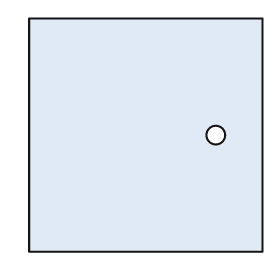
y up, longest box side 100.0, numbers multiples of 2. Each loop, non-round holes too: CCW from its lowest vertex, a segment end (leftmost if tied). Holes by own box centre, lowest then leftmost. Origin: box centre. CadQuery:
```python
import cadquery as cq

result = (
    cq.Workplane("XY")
    .moveTo(-50.0, -50.0)
    .lineTo(50.0, -50.0)
    .lineTo(50.0, 50.0)
    .lineTo(-50.0, 50.0)
    .close()
    .moveTo(30.0, 0.0)
    .circle(4.0)
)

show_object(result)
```